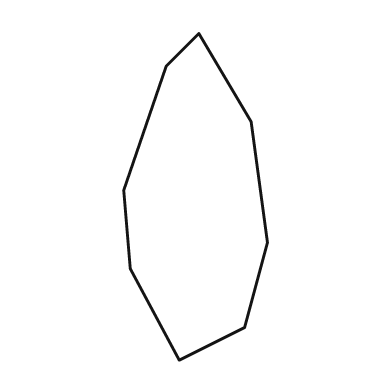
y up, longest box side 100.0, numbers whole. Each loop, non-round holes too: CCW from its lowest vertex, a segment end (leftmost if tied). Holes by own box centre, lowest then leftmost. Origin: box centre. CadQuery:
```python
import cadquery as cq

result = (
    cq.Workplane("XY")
    .moveTo(-5.0, -50.0)
    .lineTo(15.0, -40.0)
    .lineTo(22.0, -14.0)
    .lineTo(17.0, 23.0)
    .lineTo(1.0, 50.0)
    .lineTo(-9.0, 40.0)
    .lineTo(-22.0, 2.0)
    .lineTo(-20.0, -22.0)
    .close()
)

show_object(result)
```